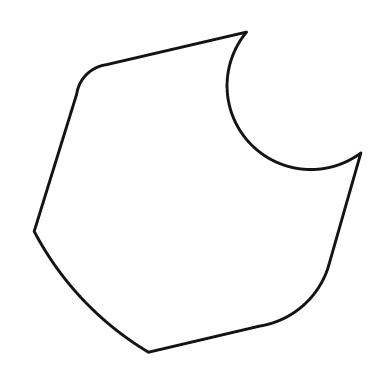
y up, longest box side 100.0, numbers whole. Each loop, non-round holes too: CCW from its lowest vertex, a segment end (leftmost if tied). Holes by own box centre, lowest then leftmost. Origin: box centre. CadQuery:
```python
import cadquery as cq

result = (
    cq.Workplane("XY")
    .moveTo(-15.0, -49.0)
    .lineTo(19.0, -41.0)
    .threePointArc((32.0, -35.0), (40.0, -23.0))
    .lineTo(50.0, 12.0)
    .threePointArc((16.0, 15.0), (15.0, 49.0))
    .lineTo(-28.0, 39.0)
    .threePointArc((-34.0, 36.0), (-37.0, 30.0))
    .lineTo(-50.0, -12.0)
    .threePointArc((-35.0, -33.0), (-15.0, -49.0))
    .close()
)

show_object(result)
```